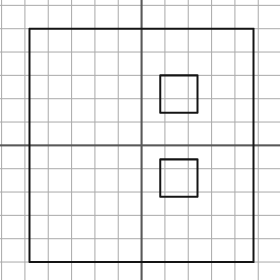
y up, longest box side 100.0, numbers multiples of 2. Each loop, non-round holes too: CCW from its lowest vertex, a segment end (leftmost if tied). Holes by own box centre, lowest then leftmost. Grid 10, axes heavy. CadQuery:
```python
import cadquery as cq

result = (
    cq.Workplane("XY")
    .moveTo(-48.0, -50.0)
    .lineTo(48.0, -50.0)
    .lineTo(48.0, 50.0)
    .lineTo(-48.0, 50.0)
    .close()
    .moveTo(8.0, -22.0)
    .lineTo(24.0, -22.0)
    .lineTo(24.0, -6.0)
    .lineTo(8.0, -6.0)
    .close()
    .moveTo(8.0, 14.0)
    .lineTo(24.0, 14.0)
    .lineTo(24.0, 30.0)
    .lineTo(8.0, 30.0)
    .close()
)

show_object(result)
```